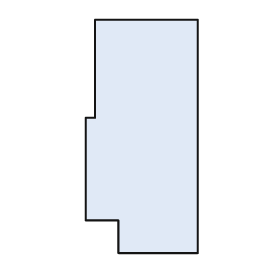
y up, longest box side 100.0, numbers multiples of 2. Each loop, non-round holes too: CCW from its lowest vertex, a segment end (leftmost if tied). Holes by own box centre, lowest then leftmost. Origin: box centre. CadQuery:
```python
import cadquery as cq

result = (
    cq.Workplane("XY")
    .moveTo(-10.0, -50.0)
    .lineTo(24.0, -50.0)
    .lineTo(24.0, 50.0)
    .lineTo(-20.0, 50.0)
    .lineTo(-20.0, 8.0)
    .lineTo(-24.0, 8.0)
    .lineTo(-24.0, -36.0)
    .lineTo(-10.0, -36.0)
    .close()
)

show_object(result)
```